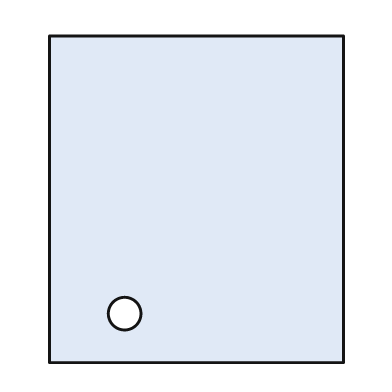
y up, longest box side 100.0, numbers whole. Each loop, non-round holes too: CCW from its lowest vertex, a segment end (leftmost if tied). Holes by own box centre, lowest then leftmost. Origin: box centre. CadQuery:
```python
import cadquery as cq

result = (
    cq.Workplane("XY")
    .moveTo(-45.0, -50.0)
    .lineTo(45.0, -50.0)
    .lineTo(45.0, 50.0)
    .lineTo(-45.0, 50.0)
    .close()
    .moveTo(-22.0, -35.0)
    .circle(5.0)
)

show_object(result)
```